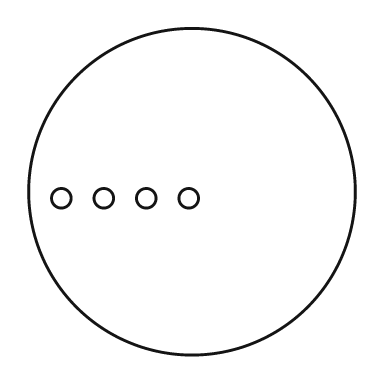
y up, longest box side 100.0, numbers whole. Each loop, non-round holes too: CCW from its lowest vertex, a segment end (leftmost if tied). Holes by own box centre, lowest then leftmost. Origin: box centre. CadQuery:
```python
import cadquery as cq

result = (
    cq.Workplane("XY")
    .moveTo(0.0, 0.0)
    .circle(50.0)
    .moveTo(-40.0, -2.0)
    .circle(3.0)
    .moveTo(-27.0, -2.0)
    .circle(3.0)
    .moveTo(-14.0, -2.0)
    .circle(3.0)
    .moveTo(-1.0, -2.0)
    .circle(3.0)
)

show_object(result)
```